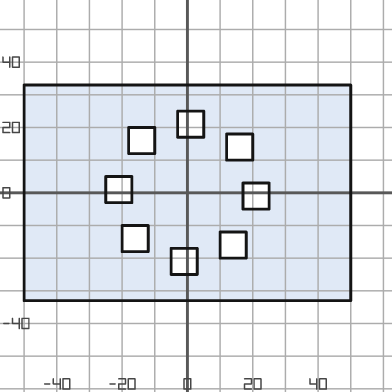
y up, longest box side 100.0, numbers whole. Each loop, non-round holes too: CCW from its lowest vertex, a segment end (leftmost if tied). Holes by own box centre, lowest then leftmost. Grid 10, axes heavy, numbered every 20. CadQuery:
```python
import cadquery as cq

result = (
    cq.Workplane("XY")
    .moveTo(-50.0, -33.0)
    .lineTo(50.0, -33.0)
    .lineTo(50.0, 33.0)
    .lineTo(-50.0, 33.0)
    .close()
    .moveTo(-5.0, -25.0)
    .lineTo(3.0, -25.0)
    .lineTo(3.0, -17.0)
    .lineTo(-5.0, -17.0)
    .close()
    .moveTo(10.0, -20.0)
    .lineTo(18.0, -20.0)
    .lineTo(18.0, -12.0)
    .lineTo(10.0, -12.0)
    .close()
    .moveTo(-20.0, -18.0)
    .lineTo(-12.0, -18.0)
    .lineTo(-12.0, -10.0)
    .lineTo(-20.0, -10.0)
    .close()
    .moveTo(17.0, -5.0)
    .lineTo(25.0, -5.0)
    .lineTo(25.0, 3.0)
    .lineTo(17.0, 3.0)
    .close()
    .moveTo(-25.0, -3.0)
    .lineTo(-17.0, -3.0)
    .lineTo(-17.0, 5.0)
    .lineTo(-25.0, 5.0)
    .close()
    .moveTo(12.0, 10.0)
    .lineTo(20.0, 10.0)
    .lineTo(20.0, 18.0)
    .lineTo(12.0, 18.0)
    .close()
    .moveTo(-18.0, 12.0)
    .lineTo(-10.0, 12.0)
    .lineTo(-10.0, 20.0)
    .lineTo(-18.0, 20.0)
    .close()
    .moveTo(-3.0, 17.0)
    .lineTo(5.0, 17.0)
    .lineTo(5.0, 25.0)
    .lineTo(-3.0, 25.0)
    .close()
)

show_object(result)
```